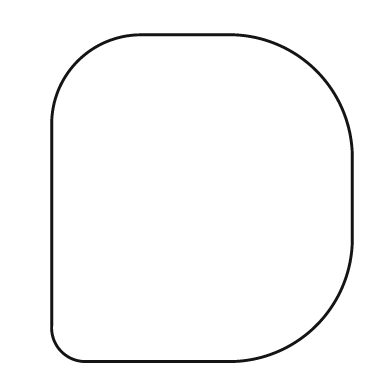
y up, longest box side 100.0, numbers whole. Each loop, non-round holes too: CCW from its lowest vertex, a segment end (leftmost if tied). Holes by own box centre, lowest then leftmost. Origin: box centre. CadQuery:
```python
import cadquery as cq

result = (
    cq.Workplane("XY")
    .moveTo(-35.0, -50.0)
    .lineTo(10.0, -50.0)
    .threePointArc((35.0, -39.0), (46.0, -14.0))
    .lineTo(46.0, 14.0)
    .threePointArc((35.0, 39.0), (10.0, 50.0))
    .lineTo(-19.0, 50.0)
    .threePointArc((-38.0, 42.0), (-46.0, 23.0))
    .lineTo(-46.0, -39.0)
    .threePointArc((-43.0, -47.0), (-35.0, -50.0))
    .close()
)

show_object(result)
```